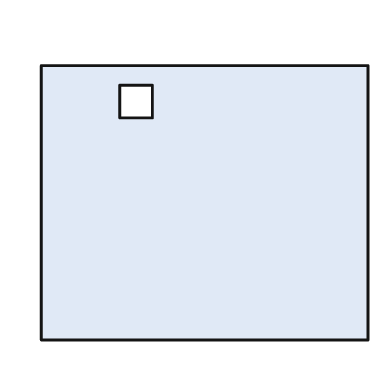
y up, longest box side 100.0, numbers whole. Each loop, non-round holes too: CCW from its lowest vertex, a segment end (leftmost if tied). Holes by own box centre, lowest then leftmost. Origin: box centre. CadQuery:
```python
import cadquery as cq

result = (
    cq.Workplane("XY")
    .moveTo(-50.0, -42.0)
    .lineTo(50.0, -42.0)
    .lineTo(50.0, 42.0)
    .lineTo(-50.0, 42.0)
    .close()
    .moveTo(-26.0, 26.0)
    .lineTo(-16.0, 26.0)
    .lineTo(-16.0, 36.0)
    .lineTo(-26.0, 36.0)
    .close()
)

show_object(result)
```